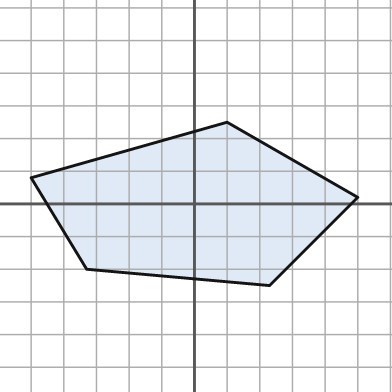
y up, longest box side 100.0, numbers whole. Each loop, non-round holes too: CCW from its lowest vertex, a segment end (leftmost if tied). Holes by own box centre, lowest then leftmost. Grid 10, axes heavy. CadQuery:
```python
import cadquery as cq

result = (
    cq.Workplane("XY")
    .moveTo(23.0, -25.0)
    .lineTo(50.0, 2.0)
    .lineTo(10.0, 25.0)
    .lineTo(-50.0, 8.0)
    .lineTo(-33.0, -20.0)
    .close()
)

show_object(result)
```